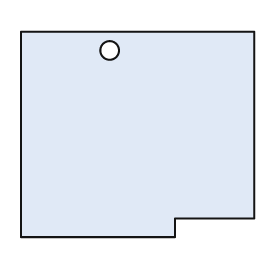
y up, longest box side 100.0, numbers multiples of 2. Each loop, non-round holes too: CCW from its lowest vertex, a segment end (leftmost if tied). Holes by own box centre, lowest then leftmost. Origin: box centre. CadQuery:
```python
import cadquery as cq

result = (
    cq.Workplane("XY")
    .moveTo(-50.0, -44.0)
    .lineTo(16.0, -44.0)
    .lineTo(16.0, -36.0)
    .lineTo(50.0, -36.0)
    .lineTo(50.0, 44.0)
    .lineTo(-50.0, 44.0)
    .close()
    .moveTo(-12.0, 36.0)
    .circle(4.0)
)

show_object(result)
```